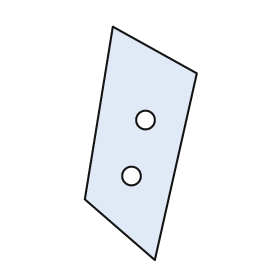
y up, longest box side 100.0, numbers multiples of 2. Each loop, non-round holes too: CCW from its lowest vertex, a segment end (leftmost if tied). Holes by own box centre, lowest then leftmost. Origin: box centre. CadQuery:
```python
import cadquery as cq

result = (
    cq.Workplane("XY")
    .moveTo(6.0, -50.0)
    .lineTo(24.0, 30.0)
    .lineTo(-12.0, 50.0)
    .lineTo(-24.0, -24.0)
    .close()
    .moveTo(-4.0, -14.0)
    .circle(4.0)
    .moveTo(2.0, 10.0)
    .circle(4.0)
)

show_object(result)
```